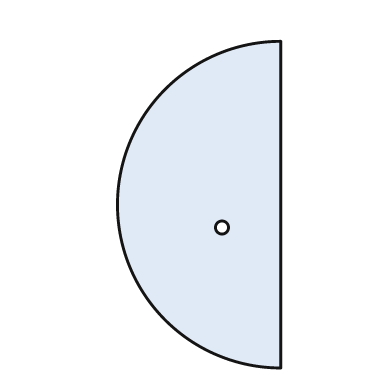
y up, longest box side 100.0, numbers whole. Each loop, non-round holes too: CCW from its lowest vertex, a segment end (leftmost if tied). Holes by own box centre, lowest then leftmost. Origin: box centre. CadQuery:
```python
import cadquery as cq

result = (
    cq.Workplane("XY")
    .moveTo(25.0, -50.0)
    .lineTo(25.0, 50.0)
    .threePointArc((-25.0, 0.0), (25.0, -50.0))
    .close()
    .moveTo(7.0, -7.0)
    .circle(2.0)
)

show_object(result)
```